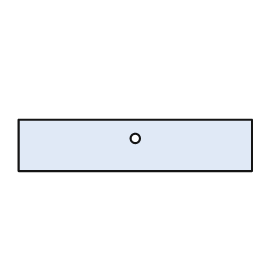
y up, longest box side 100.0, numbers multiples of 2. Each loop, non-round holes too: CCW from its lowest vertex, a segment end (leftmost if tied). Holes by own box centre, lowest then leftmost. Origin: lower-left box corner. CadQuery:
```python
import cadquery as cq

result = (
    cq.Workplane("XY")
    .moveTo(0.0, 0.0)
    .lineTo(100.0, 0.0)
    .lineTo(100.0, 22.0)
    .lineTo(0.0, 22.0)
    .close()
    .moveTo(50.0, 14.0)
    .circle(2.0)
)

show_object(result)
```